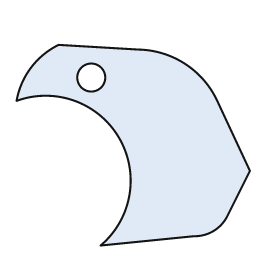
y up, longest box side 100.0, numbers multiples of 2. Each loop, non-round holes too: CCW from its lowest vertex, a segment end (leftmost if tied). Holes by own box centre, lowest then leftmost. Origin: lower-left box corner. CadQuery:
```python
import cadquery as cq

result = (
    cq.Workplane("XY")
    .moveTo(36.0, 0.0)
    .lineTo(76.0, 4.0)
    .threePointArc((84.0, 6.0), (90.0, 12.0))
    .lineTo(100.0, 32.0)
    .lineTo(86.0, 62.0)
    .threePointArc((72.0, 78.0), (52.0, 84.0))
    .lineTo(18.0, 86.0)
    .threePointArc((6.0, 76.0), (0.0, 62.0))
    .threePointArc((44.0, 46.0), (36.0, 0.0))
    .close()
    .moveTo(32.0, 72.0)
    .circle(6.0)
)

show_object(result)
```